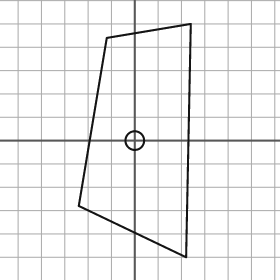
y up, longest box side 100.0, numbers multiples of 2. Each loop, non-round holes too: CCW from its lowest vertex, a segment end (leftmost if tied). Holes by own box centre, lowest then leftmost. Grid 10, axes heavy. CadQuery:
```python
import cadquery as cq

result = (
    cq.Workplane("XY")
    .moveTo(22.0, -50.0)
    .lineTo(24.0, 50.0)
    .lineTo(-12.0, 44.0)
    .lineTo(-24.0, -28.0)
    .close()
    .moveTo(0.0, 0.0)
    .circle(4.0)
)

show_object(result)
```